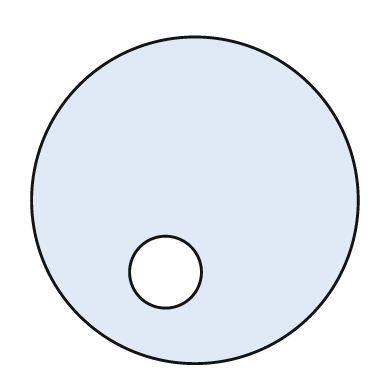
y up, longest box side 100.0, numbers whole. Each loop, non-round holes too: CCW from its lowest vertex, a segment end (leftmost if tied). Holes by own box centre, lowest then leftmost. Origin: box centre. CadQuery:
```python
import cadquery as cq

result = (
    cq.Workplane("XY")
    .moveTo(0.0, 0.0)
    .circle(50.0)
    .moveTo(-9.0, -22.0)
    .circle(11.0)
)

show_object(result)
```